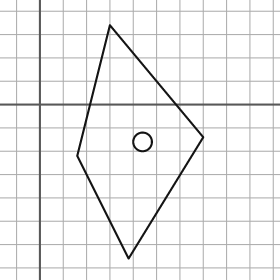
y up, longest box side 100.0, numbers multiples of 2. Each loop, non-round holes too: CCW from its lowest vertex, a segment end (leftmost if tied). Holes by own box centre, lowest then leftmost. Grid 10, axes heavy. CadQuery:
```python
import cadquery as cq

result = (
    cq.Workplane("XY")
    .moveTo(38.0, -66.0)
    .lineTo(70.0, -14.0)
    .lineTo(30.0, 34.0)
    .lineTo(16.0, -22.0)
    .close()
    .moveTo(44.0, -16.0)
    .circle(4.0)
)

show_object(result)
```